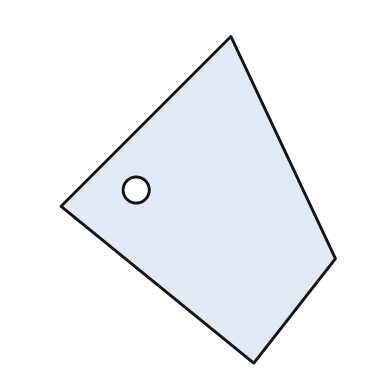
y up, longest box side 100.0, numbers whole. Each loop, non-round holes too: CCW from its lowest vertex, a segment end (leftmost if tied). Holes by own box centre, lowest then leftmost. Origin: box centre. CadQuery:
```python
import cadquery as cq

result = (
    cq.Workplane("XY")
    .moveTo(17.0, -50.0)
    .lineTo(42.0, -18.0)
    .lineTo(10.0, 50.0)
    .lineTo(-42.0, -2.0)
    .close()
    .moveTo(-19.0, 3.0)
    .circle(4.0)
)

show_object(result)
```